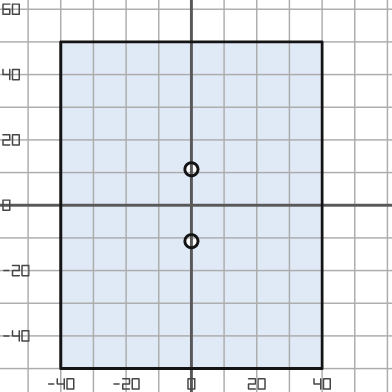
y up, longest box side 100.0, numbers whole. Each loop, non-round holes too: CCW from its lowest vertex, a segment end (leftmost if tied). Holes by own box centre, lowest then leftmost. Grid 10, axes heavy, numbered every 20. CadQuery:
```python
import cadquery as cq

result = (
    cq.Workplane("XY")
    .moveTo(-40.0, -50.0)
    .lineTo(40.0, -50.0)
    .lineTo(40.0, 50.0)
    .lineTo(-40.0, 50.0)
    .close()
    .moveTo(0.0, -11.0)
    .circle(2.0)
    .moveTo(0.0, 11.0)
    .circle(2.0)
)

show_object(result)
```